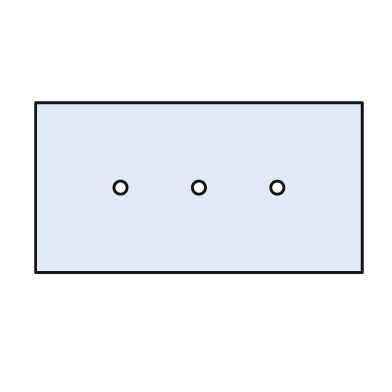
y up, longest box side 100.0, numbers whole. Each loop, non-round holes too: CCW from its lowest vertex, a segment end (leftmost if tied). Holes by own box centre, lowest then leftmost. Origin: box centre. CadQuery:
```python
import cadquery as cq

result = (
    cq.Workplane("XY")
    .moveTo(-50.0, -26.0)
    .lineTo(50.0, -26.0)
    .lineTo(50.0, 26.0)
    .lineTo(-50.0, 26.0)
    .close()
    .moveTo(-24.0, 0.0)
    .circle(2.0)
    .moveTo(0.0, 0.0)
    .circle(2.0)
    .moveTo(24.0, 0.0)
    .circle(2.0)
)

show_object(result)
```